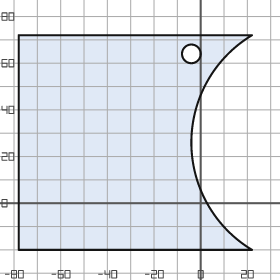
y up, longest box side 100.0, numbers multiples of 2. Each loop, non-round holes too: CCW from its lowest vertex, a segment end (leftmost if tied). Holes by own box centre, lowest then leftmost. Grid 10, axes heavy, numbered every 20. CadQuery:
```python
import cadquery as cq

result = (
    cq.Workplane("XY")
    .moveTo(-78.0, -20.0)
    .lineTo(22.0, -20.0)
    .threePointArc((-4.0, 26.0), (22.0, 72.0))
    .lineTo(-78.0, 72.0)
    .close()
    .moveTo(-4.0, 64.0)
    .circle(4.0)
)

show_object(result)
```